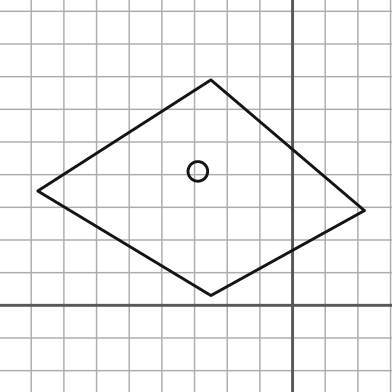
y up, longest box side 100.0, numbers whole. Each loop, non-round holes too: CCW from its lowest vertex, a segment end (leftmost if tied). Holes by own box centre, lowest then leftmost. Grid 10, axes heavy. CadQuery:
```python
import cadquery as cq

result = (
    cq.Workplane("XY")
    .moveTo(-25.0, 3.0)
    .lineTo(22.0, 29.0)
    .lineTo(-25.0, 69.0)
    .lineTo(-78.0, 35.0)
    .close()
    .moveTo(-29.0, 41.0)
    .circle(3.0)
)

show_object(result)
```